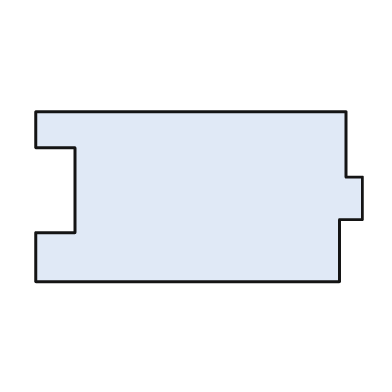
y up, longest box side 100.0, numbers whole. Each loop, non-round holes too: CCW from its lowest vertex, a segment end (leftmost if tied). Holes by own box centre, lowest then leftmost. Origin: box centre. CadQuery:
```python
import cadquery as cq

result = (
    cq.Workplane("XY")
    .moveTo(-50.0, -26.0)
    .lineTo(43.0, -26.0)
    .lineTo(43.0, -7.0)
    .lineTo(50.0, -7.0)
    .lineTo(50.0, 6.0)
    .lineTo(45.0, 6.0)
    .lineTo(45.0, 26.0)
    .lineTo(-50.0, 26.0)
    .lineTo(-50.0, 15.0)
    .lineTo(-38.0, 15.0)
    .lineTo(-38.0, -11.0)
    .lineTo(-50.0, -11.0)
    .close()
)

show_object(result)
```